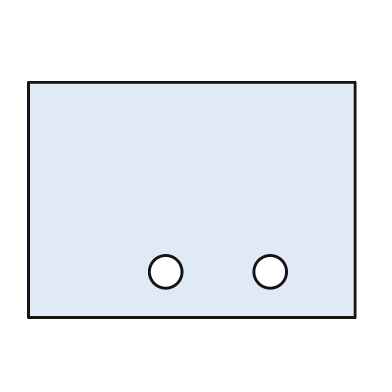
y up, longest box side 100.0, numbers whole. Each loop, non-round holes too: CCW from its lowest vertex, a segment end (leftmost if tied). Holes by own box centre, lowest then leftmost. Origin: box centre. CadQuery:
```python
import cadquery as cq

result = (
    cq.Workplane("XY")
    .moveTo(-50.0, -36.0)
    .lineTo(50.0, -36.0)
    .lineTo(50.0, 36.0)
    .lineTo(-50.0, 36.0)
    .close()
    .moveTo(-8.0, -22.0)
    .circle(5.0)
    .moveTo(24.0, -22.0)
    .circle(5.0)
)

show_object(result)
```